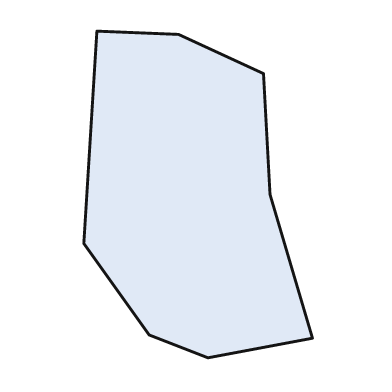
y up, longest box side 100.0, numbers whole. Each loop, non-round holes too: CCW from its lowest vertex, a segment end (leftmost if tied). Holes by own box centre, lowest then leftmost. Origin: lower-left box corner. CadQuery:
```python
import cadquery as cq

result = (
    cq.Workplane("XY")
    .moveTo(38.0, 0.0)
    .lineTo(70.0, 6.0)
    .lineTo(57.0, 50.0)
    .lineTo(55.0, 87.0)
    .lineTo(29.0, 99.0)
    .lineTo(4.0, 100.0)
    .lineTo(0.0, 35.0)
    .lineTo(20.0, 7.0)
    .close()
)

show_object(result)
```